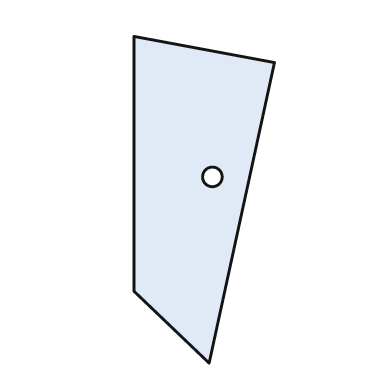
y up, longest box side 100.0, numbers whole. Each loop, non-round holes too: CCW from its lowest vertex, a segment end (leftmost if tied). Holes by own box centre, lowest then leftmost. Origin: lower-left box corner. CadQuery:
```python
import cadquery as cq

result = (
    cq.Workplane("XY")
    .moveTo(23.0, 0.0)
    .lineTo(43.0, 92.0)
    .lineTo(0.0, 100.0)
    .lineTo(0.0, 22.0)
    .close()
    .moveTo(24.0, 57.0)
    .circle(3.0)
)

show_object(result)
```